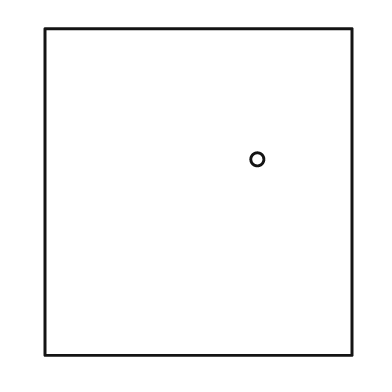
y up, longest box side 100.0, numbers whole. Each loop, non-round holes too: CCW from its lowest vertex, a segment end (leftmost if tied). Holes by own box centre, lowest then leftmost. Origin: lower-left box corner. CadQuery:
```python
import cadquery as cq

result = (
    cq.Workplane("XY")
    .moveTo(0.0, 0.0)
    .lineTo(94.0, 0.0)
    .lineTo(94.0, 100.0)
    .lineTo(0.0, 100.0)
    .close()
    .moveTo(65.0, 60.0)
    .circle(2.0)
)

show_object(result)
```